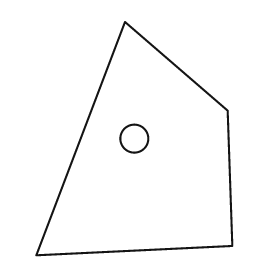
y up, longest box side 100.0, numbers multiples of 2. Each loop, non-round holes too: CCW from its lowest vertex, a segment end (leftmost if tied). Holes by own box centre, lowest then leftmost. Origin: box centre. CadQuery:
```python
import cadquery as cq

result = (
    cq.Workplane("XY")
    .moveTo(-42.0, -50.0)
    .lineTo(42.0, -46.0)
    .lineTo(40.0, 12.0)
    .lineTo(-4.0, 50.0)
    .close()
    .moveTo(0.0, 0.0)
    .circle(6.0)
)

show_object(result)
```